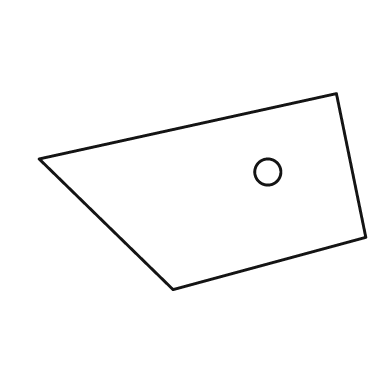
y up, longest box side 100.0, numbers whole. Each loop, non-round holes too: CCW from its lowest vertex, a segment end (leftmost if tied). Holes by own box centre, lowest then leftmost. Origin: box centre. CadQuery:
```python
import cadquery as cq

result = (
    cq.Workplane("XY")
    .moveTo(-9.0, -30.0)
    .lineTo(50.0, -14.0)
    .lineTo(41.0, 30.0)
    .lineTo(-50.0, 10.0)
    .close()
    .moveTo(20.0, 6.0)
    .circle(4.0)
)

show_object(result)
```